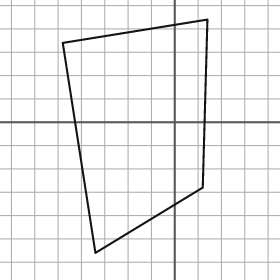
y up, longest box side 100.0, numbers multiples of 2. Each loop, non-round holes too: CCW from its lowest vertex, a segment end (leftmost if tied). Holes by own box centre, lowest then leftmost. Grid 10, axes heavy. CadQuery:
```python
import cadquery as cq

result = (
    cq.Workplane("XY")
    .moveTo(-34.0, -56.0)
    .lineTo(12.0, -28.0)
    .lineTo(14.0, 44.0)
    .lineTo(-48.0, 34.0)
    .close()
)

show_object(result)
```